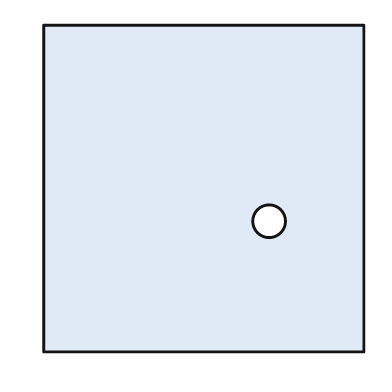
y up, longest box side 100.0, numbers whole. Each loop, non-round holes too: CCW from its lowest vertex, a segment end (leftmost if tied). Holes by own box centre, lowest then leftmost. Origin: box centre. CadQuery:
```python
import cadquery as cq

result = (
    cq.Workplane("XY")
    .moveTo(-49.0, -50.0)
    .lineTo(49.0, -50.0)
    .lineTo(49.0, 50.0)
    .lineTo(-49.0, 50.0)
    .close()
    .moveTo(20.0, -10.0)
    .circle(5.0)
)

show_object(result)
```